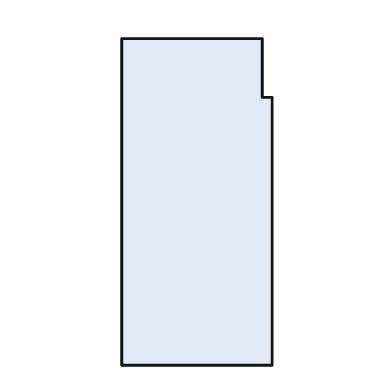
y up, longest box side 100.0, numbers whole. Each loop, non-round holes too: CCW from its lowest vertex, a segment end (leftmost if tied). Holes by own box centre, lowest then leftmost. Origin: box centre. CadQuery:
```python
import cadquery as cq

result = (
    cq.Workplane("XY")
    .moveTo(-23.0, -50.0)
    .lineTo(23.0, -50.0)
    .lineTo(23.0, 32.0)
    .lineTo(20.0, 32.0)
    .lineTo(20.0, 50.0)
    .lineTo(-23.0, 50.0)
    .close()
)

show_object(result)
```